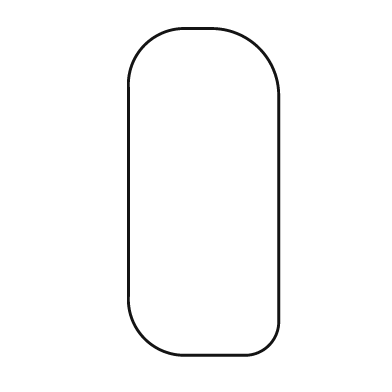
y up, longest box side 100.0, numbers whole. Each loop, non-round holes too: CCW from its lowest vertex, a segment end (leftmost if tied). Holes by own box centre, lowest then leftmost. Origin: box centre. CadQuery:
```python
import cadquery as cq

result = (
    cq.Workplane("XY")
    .moveTo(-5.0, -50.0)
    .lineTo(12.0, -50.0)
    .threePointArc((20.0, -47.0), (23.0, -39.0))
    .lineTo(23.0, 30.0)
    .threePointArc((17.0, 44.0), (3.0, 50.0))
    .lineTo(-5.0, 50.0)
    .threePointArc((-18.0, 45.0), (-23.0, 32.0))
    .lineTo(-23.0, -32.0)
    .threePointArc((-18.0, -45.0), (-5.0, -50.0))
    .close()
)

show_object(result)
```